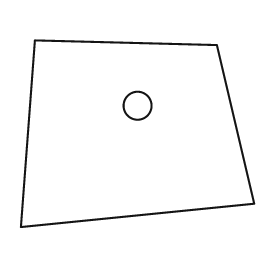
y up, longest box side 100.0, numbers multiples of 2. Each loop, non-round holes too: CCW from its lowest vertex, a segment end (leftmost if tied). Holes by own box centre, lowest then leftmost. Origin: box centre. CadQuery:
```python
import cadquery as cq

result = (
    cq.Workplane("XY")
    .moveTo(-50.0, -40.0)
    .lineTo(50.0, -30.0)
    .lineTo(34.0, 38.0)
    .lineTo(-44.0, 40.0)
    .close()
    .moveTo(0.0, 12.0)
    .circle(6.0)
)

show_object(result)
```